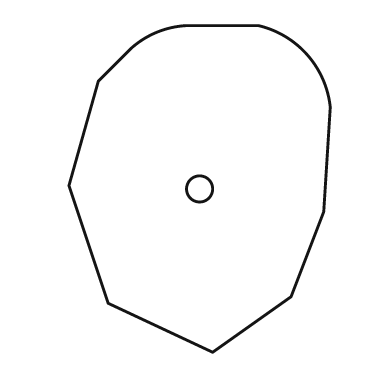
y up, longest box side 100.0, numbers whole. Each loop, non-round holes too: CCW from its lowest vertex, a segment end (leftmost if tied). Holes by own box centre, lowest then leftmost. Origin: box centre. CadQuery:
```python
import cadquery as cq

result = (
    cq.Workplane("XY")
    .moveTo(4.0, -50.0)
    .lineTo(28.0, -33.0)
    .lineTo(38.0, -7.0)
    .lineTo(40.0, 25.0)
    .threePointArc((33.0, 41.0), (18.0, 50.0))
    .lineTo(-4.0, 50.0)
    .threePointArc((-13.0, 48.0), (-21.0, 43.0))
    .lineTo(-31.0, 33.0)
    .lineTo(-40.0, 1.0)
    .lineTo(-28.0, -35.0)
    .close()
    .moveTo(0.0, 0.0)
    .circle(4.0)
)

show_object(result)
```